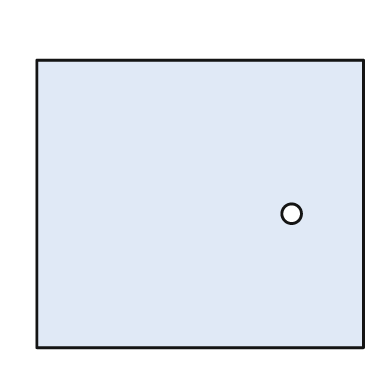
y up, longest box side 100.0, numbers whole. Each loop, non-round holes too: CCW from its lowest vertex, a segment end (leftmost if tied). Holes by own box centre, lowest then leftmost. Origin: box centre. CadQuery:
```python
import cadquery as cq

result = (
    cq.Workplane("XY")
    .moveTo(-50.0, -44.0)
    .lineTo(50.0, -44.0)
    .lineTo(50.0, 44.0)
    .lineTo(-50.0, 44.0)
    .close()
    .moveTo(28.0, -3.0)
    .circle(3.0)
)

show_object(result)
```